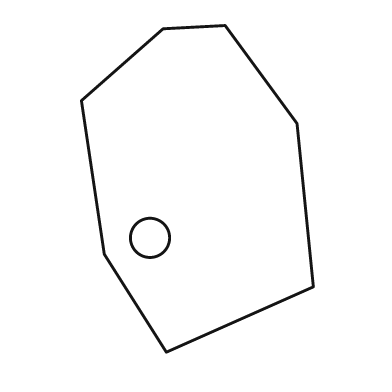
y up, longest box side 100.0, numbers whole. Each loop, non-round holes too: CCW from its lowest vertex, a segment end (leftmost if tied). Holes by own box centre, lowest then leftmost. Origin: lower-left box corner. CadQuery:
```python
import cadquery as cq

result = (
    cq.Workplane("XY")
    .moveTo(26.0, 0.0)
    .lineTo(71.0, 20.0)
    .lineTo(66.0, 70.0)
    .lineTo(44.0, 100.0)
    .lineTo(25.0, 99.0)
    .lineTo(0.0, 77.0)
    .lineTo(7.0, 30.0)
    .close()
    .moveTo(21.0, 35.0)
    .circle(6.0)
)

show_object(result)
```